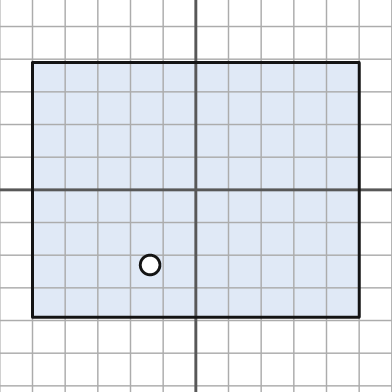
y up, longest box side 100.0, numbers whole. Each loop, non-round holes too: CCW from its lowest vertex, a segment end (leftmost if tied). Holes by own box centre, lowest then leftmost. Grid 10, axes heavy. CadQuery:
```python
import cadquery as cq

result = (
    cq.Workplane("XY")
    .moveTo(-50.0, -39.0)
    .lineTo(50.0, -39.0)
    .lineTo(50.0, 39.0)
    .lineTo(-50.0, 39.0)
    .close()
    .moveTo(-14.0, -23.0)
    .circle(3.0)
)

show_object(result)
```